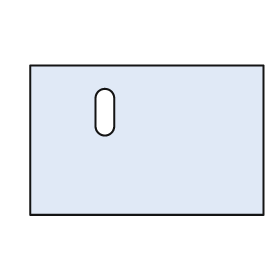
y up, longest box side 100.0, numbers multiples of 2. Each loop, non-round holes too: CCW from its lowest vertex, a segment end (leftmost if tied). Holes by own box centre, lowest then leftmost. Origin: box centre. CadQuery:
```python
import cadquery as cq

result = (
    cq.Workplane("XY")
    .moveTo(-50.0, -32.0)
    .lineTo(50.0, -32.0)
    .lineTo(50.0, 32.0)
    .lineTo(-50.0, 32.0)
    .close()
    .moveTo(-22.0, 6.0)
    .threePointArc((-18.0, 2.0), (-14.0, 6.0))
    .lineTo(-14.0, 18.0)
    .threePointArc((-18.0, 22.0), (-22.0, 18.0))
    .close()
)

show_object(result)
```